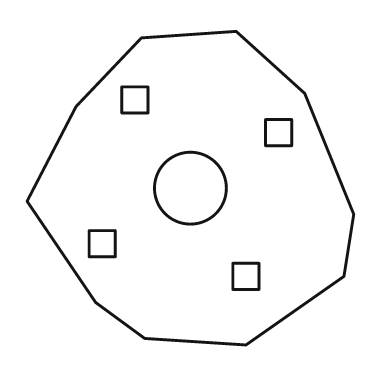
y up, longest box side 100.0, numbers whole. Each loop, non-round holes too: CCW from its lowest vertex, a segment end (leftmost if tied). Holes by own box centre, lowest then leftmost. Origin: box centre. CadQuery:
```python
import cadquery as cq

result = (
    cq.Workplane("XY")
    .moveTo(17.0, -48.0)
    .lineTo(47.0, -27.0)
    .lineTo(50.0, -8.0)
    .lineTo(35.0, 29.0)
    .lineTo(14.0, 48.0)
    .lineTo(-15.0, 46.0)
    .lineTo(-35.0, 25.0)
    .lineTo(-50.0, -4.0)
    .lineTo(-29.0, -35.0)
    .lineTo(-14.0, -46.0)
    .close()
    .moveTo(13.0, -31.0)
    .lineTo(21.0, -31.0)
    .lineTo(21.0, -23.0)
    .lineTo(13.0, -23.0)
    .close()
    .moveTo(-31.0, -21.0)
    .lineTo(-23.0, -21.0)
    .lineTo(-23.0, -13.0)
    .lineTo(-31.0, -13.0)
    .close()
    .moveTo(0.0, 0.0)
    .circle(11.0)
    .moveTo(23.0, 13.0)
    .lineTo(31.0, 13.0)
    .lineTo(31.0, 21.0)
    .lineTo(23.0, 21.0)
    .close()
    .moveTo(-21.0, 23.0)
    .lineTo(-13.0, 23.0)
    .lineTo(-13.0, 31.0)
    .lineTo(-21.0, 31.0)
    .close()
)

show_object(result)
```